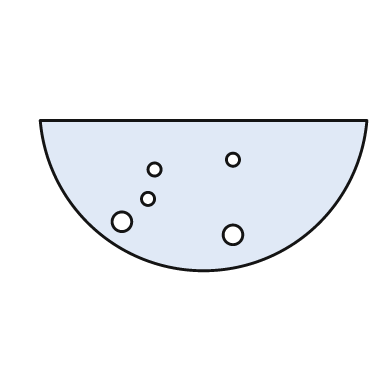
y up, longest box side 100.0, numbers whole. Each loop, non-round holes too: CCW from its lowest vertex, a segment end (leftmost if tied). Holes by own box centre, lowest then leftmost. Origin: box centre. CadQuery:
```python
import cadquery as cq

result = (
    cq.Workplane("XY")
    .moveTo(-50.0, 23.0)
    .threePointArc((0.0, -23.0), (50.0, 23.0))
    .close()
    .moveTo(9.0, -12.0)
    .circle(3.0)
    .moveTo(-25.0, -8.0)
    .circle(3.0)
    .moveTo(-17.0, -1.0)
    .circle(2.0)
    .moveTo(-15.0, 8.0)
    .circle(2.0)
    .moveTo(9.0, 11.0)
    .circle(2.0)
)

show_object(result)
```